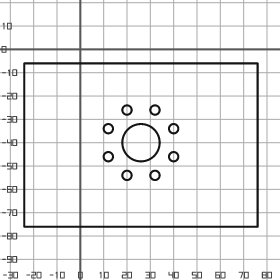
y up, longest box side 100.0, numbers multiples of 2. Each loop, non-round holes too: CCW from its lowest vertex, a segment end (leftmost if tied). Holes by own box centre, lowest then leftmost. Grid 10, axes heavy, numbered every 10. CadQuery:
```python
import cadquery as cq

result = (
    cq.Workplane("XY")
    .moveTo(-24.0, -76.0)
    .lineTo(76.0, -76.0)
    .lineTo(76.0, -6.0)
    .lineTo(-24.0, -6.0)
    .close()
    .moveTo(20.0, -54.0)
    .circle(2.0)
    .moveTo(32.0, -54.0)
    .circle(2.0)
    .moveTo(12.0, -46.0)
    .circle(2.0)
    .moveTo(40.0, -46.0)
    .circle(2.0)
    .moveTo(26.0, -40.0)
    .circle(8.0)
    .moveTo(12.0, -34.0)
    .circle(2.0)
    .moveTo(40.0, -34.0)
    .circle(2.0)
    .moveTo(20.0, -26.0)
    .circle(2.0)
    .moveTo(32.0, -26.0)
    .circle(2.0)
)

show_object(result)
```